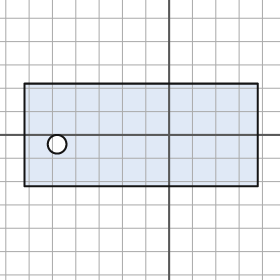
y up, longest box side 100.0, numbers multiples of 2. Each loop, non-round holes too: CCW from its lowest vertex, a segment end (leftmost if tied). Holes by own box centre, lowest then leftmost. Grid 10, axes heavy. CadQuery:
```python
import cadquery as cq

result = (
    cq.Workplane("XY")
    .moveTo(-62.0, -22.0)
    .lineTo(38.0, -22.0)
    .lineTo(38.0, 22.0)
    .lineTo(-62.0, 22.0)
    .close()
    .moveTo(-48.0, -4.0)
    .circle(4.0)
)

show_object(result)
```